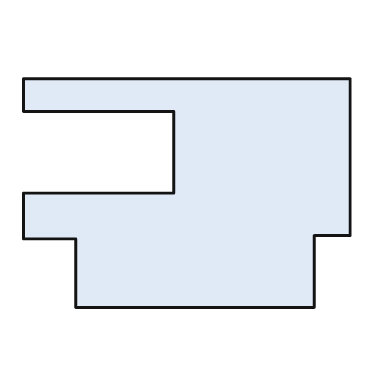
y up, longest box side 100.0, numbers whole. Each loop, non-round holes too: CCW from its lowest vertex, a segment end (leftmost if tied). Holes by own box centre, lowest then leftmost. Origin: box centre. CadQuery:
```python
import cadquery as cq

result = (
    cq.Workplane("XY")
    .moveTo(-34.0, -35.0)
    .lineTo(39.0, -35.0)
    .lineTo(39.0, -13.0)
    .lineTo(50.0, -13.0)
    .lineTo(50.0, 35.0)
    .lineTo(-50.0, 35.0)
    .lineTo(-50.0, 25.0)
    .lineTo(-4.0, 25.0)
    .lineTo(-4.0, 0.0)
    .lineTo(-50.0, 0.0)
    .lineTo(-50.0, -14.0)
    .lineTo(-34.0, -14.0)
    .close()
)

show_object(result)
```